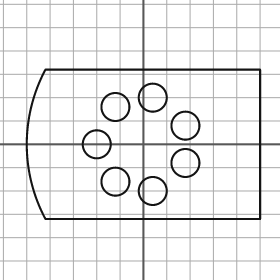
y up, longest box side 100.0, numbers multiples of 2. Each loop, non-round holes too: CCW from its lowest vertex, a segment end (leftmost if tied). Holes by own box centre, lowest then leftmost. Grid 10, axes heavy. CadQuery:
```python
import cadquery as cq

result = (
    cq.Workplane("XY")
    .moveTo(-42.0, -32.0)
    .lineTo(50.0, -32.0)
    .lineTo(50.0, 32.0)
    .lineTo(-42.0, 32.0)
    .threePointArc((-50.0, 0.0), (-42.0, -32.0))
    .close()
    .moveTo(4.0, -20.0)
    .circle(6.0)
    .moveTo(-12.0, -16.0)
    .circle(6.0)
    .moveTo(18.0, -8.0)
    .circle(6.0)
    .moveTo(-20.0, 0.0)
    .circle(6.0)
    .moveTo(18.0, 8.0)
    .circle(6.0)
    .moveTo(-12.0, 16.0)
    .circle(6.0)
    .moveTo(4.0, 20.0)
    .circle(6.0)
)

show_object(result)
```